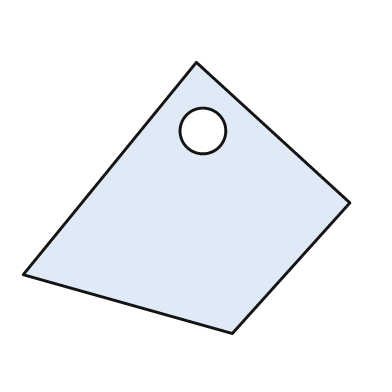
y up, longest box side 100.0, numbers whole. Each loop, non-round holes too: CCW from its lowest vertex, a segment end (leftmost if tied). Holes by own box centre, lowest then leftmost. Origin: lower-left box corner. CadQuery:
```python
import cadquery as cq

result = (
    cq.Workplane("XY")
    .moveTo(64.0, 0.0)
    .lineTo(100.0, 40.0)
    .lineTo(53.0, 83.0)
    .lineTo(0.0, 18.0)
    .close()
    .moveTo(55.0, 62.0)
    .circle(7.0)
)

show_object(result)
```